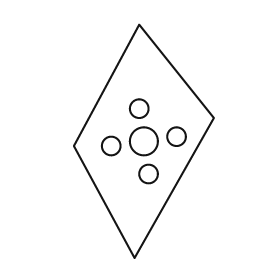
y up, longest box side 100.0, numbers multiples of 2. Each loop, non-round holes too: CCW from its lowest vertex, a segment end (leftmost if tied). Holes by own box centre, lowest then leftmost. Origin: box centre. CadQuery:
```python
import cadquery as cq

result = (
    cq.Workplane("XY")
    .moveTo(-4.0, -50.0)
    .lineTo(30.0, 10.0)
    .lineTo(-2.0, 50.0)
    .lineTo(-30.0, -2.0)
    .close()
    .moveTo(2.0, -14.0)
    .circle(4.0)
    .moveTo(-14.0, -2.0)
    .circle(4.0)
    .moveTo(0.0, 0.0)
    .circle(6.0)
    .moveTo(14.0, 2.0)
    .circle(4.0)
    .moveTo(-2.0, 14.0)
    .circle(4.0)
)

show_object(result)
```